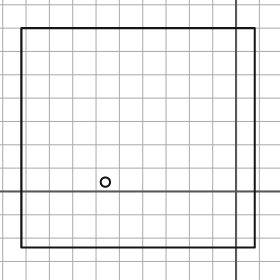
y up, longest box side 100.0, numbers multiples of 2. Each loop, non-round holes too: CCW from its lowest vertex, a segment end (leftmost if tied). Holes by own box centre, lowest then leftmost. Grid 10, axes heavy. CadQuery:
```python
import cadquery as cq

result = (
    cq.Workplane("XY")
    .moveTo(-92.0, -24.0)
    .lineTo(8.0, -24.0)
    .lineTo(8.0, 70.0)
    .lineTo(-92.0, 70.0)
    .close()
    .moveTo(-56.0, 4.0)
    .circle(2.0)
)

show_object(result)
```